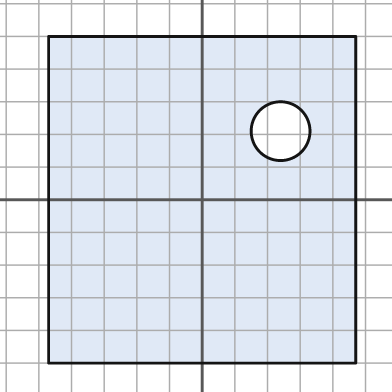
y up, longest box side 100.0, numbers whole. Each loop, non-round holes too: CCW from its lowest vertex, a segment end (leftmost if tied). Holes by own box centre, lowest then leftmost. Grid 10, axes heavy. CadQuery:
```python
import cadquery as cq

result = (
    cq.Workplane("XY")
    .moveTo(-47.0, -50.0)
    .lineTo(47.0, -50.0)
    .lineTo(47.0, 50.0)
    .lineTo(-47.0, 50.0)
    .close()
    .moveTo(24.0, 21.0)
    .circle(9.0)
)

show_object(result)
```